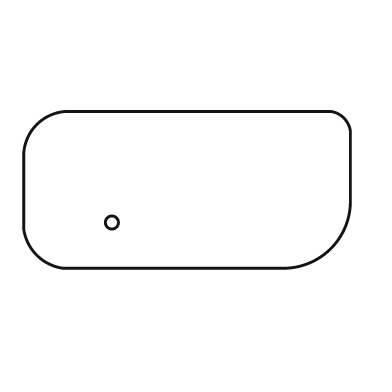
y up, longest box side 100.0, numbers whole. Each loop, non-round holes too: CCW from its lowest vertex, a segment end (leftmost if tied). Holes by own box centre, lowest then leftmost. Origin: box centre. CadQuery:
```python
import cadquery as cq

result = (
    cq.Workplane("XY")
    .moveTo(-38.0, -24.0)
    .lineTo(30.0, -24.0)
    .threePointArc((44.0, -18.0), (50.0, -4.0))
    .lineTo(50.0, 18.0)
    .threePointArc((48.0, 22.0), (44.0, 24.0))
    .lineTo(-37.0, 24.0)
    .threePointArc((-46.0, 20.0), (-50.0, 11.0))
    .lineTo(-50.0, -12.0)
    .threePointArc((-46.0, -20.0), (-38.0, -24.0))
    .close()
    .moveTo(-23.0, -10.0)
    .circle(2.0)
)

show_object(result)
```